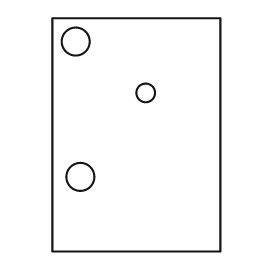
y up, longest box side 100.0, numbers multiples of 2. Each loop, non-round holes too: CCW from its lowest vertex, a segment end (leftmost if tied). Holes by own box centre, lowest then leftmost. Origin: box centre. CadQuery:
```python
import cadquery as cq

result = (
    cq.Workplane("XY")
    .moveTo(-36.0, -50.0)
    .lineTo(36.0, -50.0)
    .lineTo(36.0, 50.0)
    .lineTo(-36.0, 50.0)
    .close()
    .moveTo(-24.0, -18.0)
    .circle(6.0)
    .moveTo(4.0, 18.0)
    .circle(4.0)
    .moveTo(-26.0, 40.0)
    .circle(6.0)
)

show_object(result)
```